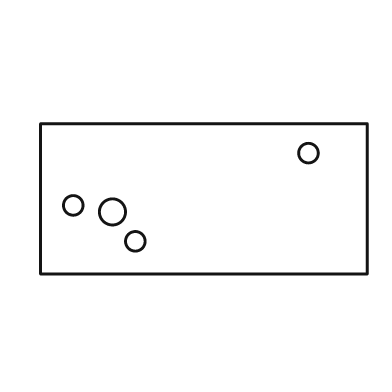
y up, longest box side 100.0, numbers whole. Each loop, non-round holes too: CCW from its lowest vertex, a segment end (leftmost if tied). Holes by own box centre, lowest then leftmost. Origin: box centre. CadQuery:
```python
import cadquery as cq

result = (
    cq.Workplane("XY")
    .moveTo(-50.0, -23.0)
    .lineTo(50.0, -23.0)
    .lineTo(50.0, 23.0)
    .lineTo(-50.0, 23.0)
    .close()
    .moveTo(-21.0, -13.0)
    .circle(3.0)
    .moveTo(-28.0, -4.0)
    .circle(4.0)
    .moveTo(-40.0, -2.0)
    .circle(3.0)
    .moveTo(32.0, 14.0)
    .circle(3.0)
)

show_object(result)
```